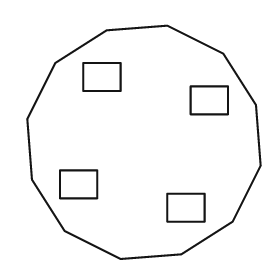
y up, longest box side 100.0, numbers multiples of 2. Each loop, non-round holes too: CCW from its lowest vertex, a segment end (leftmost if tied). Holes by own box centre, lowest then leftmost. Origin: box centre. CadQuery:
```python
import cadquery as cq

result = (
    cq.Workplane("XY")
    .moveTo(-10.0, -50.0)
    .lineTo(16.0, -48.0)
    .lineTo(38.0, -34.0)
    .lineTo(50.0, -10.0)
    .lineTo(48.0, 16.0)
    .lineTo(34.0, 38.0)
    .lineTo(10.0, 50.0)
    .lineTo(-16.0, 48.0)
    .lineTo(-38.0, 34.0)
    .lineTo(-50.0, 10.0)
    .lineTo(-48.0, -16.0)
    .lineTo(-34.0, -38.0)
    .close()
    .moveTo(10.0, -34.0)
    .lineTo(26.0, -34.0)
    .lineTo(26.0, -22.0)
    .lineTo(10.0, -22.0)
    .close()
    .moveTo(-36.0, -24.0)
    .lineTo(-20.0, -24.0)
    .lineTo(-20.0, -12.0)
    .lineTo(-36.0, -12.0)
    .close()
    .moveTo(20.0, 12.0)
    .lineTo(36.0, 12.0)
    .lineTo(36.0, 24.0)
    .lineTo(20.0, 24.0)
    .close()
    .moveTo(-26.0, 22.0)
    .lineTo(-10.0, 22.0)
    .lineTo(-10.0, 34.0)
    .lineTo(-26.0, 34.0)
    .close()
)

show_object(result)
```